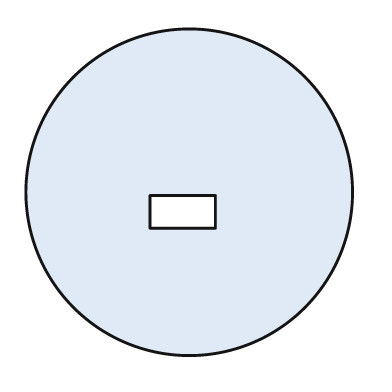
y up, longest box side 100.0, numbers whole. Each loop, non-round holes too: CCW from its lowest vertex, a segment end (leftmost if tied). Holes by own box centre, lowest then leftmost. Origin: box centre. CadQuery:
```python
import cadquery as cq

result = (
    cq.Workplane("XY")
    .moveTo(0.0, 0.0)
    .circle(50.0)
    .moveTo(-12.0, -11.0)
    .lineTo(8.0, -11.0)
    .lineTo(8.0, -1.0)
    .lineTo(-12.0, -1.0)
    .close()
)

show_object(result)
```